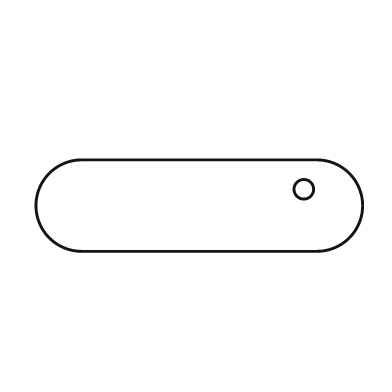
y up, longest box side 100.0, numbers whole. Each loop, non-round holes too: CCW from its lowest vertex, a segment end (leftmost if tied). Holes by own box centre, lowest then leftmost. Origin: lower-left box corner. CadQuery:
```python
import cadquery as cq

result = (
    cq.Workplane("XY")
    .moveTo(14.0, 0.0)
    .lineTo(86.0, 0.0)
    .threePointArc((100.0, 14.0), (86.0, 28.0))
    .lineTo(14.0, 28.0)
    .threePointArc((0.0, 14.0), (14.0, 0.0))
    .close()
    .moveTo(82.0, 19.0)
    .circle(3.0)
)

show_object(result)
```